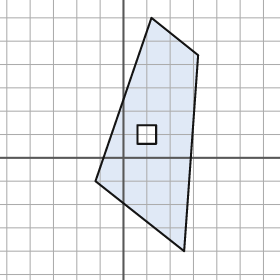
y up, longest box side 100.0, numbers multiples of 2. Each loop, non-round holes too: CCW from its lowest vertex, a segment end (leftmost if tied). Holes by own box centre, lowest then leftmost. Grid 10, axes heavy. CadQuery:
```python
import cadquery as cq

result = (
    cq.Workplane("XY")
    .moveTo(26.0, -40.0)
    .lineTo(32.0, 44.0)
    .lineTo(12.0, 60.0)
    .lineTo(-12.0, -10.0)
    .close()
    .moveTo(6.0, 6.0)
    .lineTo(14.0, 6.0)
    .lineTo(14.0, 14.0)
    .lineTo(6.0, 14.0)
    .close()
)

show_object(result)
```